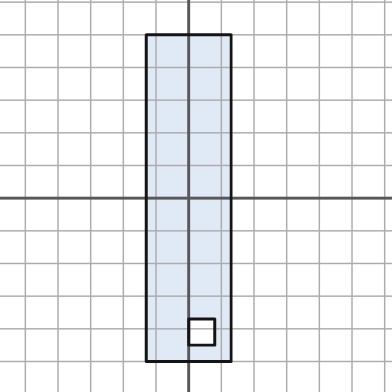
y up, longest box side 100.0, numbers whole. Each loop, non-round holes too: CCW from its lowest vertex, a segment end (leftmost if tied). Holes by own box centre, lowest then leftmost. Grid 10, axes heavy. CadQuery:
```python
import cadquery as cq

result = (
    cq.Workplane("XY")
    .moveTo(-13.0, -50.0)
    .lineTo(13.0, -50.0)
    .lineTo(13.0, 50.0)
    .lineTo(-13.0, 50.0)
    .close()
    .moveTo(0.0, -45.0)
    .lineTo(8.0, -45.0)
    .lineTo(8.0, -37.0)
    .lineTo(0.0, -37.0)
    .close()
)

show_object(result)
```